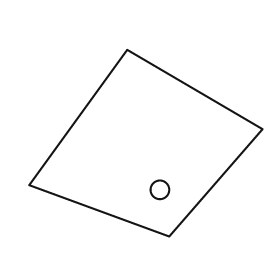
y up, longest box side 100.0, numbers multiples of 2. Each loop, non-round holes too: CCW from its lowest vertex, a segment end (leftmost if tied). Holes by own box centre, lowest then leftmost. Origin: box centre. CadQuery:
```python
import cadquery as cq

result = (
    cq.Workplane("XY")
    .moveTo(10.0, -40.0)
    .lineTo(50.0, 6.0)
    .lineTo(-8.0, 40.0)
    .lineTo(-50.0, -18.0)
    .close()
    .moveTo(6.0, -20.0)
    .circle(4.0)
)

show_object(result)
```